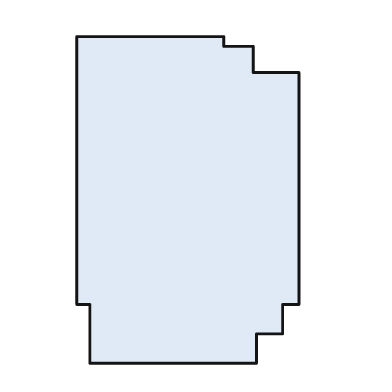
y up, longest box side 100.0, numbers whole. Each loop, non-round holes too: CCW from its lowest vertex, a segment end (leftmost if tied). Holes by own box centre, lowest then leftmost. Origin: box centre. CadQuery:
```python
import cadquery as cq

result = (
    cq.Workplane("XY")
    .moveTo(-30.0, -50.0)
    .lineTo(21.0, -50.0)
    .lineTo(21.0, -41.0)
    .lineTo(29.0, -41.0)
    .lineTo(29.0, -32.0)
    .lineTo(34.0, -32.0)
    .lineTo(34.0, 39.0)
    .lineTo(20.0, 39.0)
    .lineTo(20.0, 47.0)
    .lineTo(11.0, 47.0)
    .lineTo(11.0, 50.0)
    .lineTo(-34.0, 50.0)
    .lineTo(-34.0, -32.0)
    .lineTo(-30.0, -32.0)
    .close()
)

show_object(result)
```